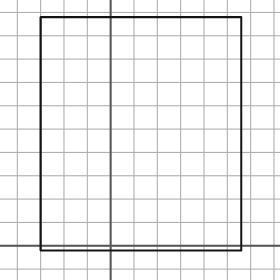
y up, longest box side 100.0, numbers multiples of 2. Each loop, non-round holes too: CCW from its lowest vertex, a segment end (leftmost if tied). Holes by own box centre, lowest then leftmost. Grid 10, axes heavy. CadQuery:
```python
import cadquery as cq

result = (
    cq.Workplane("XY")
    .moveTo(-30.0, -2.0)
    .lineTo(56.0, -2.0)
    .lineTo(56.0, 98.0)
    .lineTo(-30.0, 98.0)
    .close()
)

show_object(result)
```